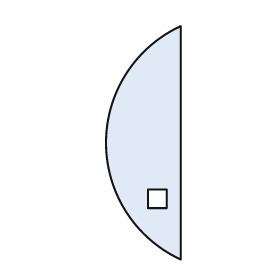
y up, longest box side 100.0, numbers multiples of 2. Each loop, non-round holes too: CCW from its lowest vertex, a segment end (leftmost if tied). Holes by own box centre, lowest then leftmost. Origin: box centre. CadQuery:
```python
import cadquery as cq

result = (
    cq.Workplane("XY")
    .moveTo(16.0, -50.0)
    .lineTo(16.0, 50.0)
    .threePointArc((-16.0, 0.0), (16.0, -50.0))
    .close()
    .moveTo(2.0, -28.0)
    .lineTo(10.0, -28.0)
    .lineTo(10.0, -20.0)
    .lineTo(2.0, -20.0)
    .close()
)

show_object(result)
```